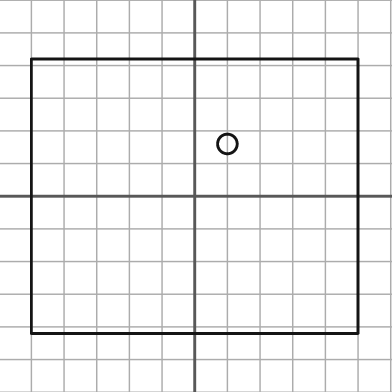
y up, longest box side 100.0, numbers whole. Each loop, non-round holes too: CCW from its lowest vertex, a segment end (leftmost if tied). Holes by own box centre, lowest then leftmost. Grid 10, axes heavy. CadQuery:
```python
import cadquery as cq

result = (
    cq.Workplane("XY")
    .moveTo(-50.0, -42.0)
    .lineTo(50.0, -42.0)
    .lineTo(50.0, 42.0)
    .lineTo(-50.0, 42.0)
    .close()
    .moveTo(10.0, 16.0)
    .circle(3.0)
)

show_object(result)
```